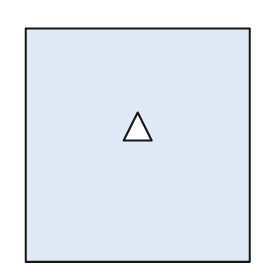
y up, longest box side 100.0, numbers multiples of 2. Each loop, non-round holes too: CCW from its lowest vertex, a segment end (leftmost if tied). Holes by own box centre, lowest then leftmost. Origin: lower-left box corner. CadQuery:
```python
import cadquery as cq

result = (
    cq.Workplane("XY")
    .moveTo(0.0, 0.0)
    .lineTo(96.0, 0.0)
    .lineTo(96.0, 100.0)
    .lineTo(0.0, 100.0)
    .close()
    .moveTo(42.0, 52.0)
    .lineTo(54.0, 52.0)
    .lineTo(48.0, 64.0)
    .close()
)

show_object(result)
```